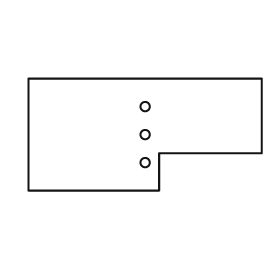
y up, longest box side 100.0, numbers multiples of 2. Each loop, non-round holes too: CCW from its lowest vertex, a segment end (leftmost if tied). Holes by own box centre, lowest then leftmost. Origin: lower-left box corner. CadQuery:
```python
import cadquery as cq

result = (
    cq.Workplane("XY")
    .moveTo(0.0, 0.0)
    .lineTo(56.0, 0.0)
    .lineTo(56.0, 16.0)
    .lineTo(100.0, 16.0)
    .lineTo(100.0, 48.0)
    .lineTo(0.0, 48.0)
    .close()
    .moveTo(50.0, 12.0)
    .circle(2.0)
    .moveTo(50.0, 24.0)
    .circle(2.0)
    .moveTo(50.0, 36.0)
    .circle(2.0)
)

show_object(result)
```